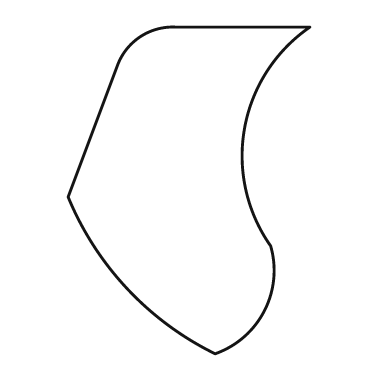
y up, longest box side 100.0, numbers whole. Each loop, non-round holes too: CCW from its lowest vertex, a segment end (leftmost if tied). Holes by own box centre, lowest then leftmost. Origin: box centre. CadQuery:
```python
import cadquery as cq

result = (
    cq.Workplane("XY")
    .moveTo(8.0, -50.0)
    .threePointArc((23.0, -37.0), (25.0, -17.0))
    .threePointArc((17.0, 19.0), (37.0, 50.0))
    .lineTo(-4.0, 50.0)
    .threePointArc((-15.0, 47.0), (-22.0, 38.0))
    .lineTo(-37.0, -2.0)
    .threePointArc((-19.0, -30.0), (8.0, -50.0))
    .close()
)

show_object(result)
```